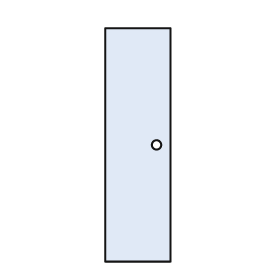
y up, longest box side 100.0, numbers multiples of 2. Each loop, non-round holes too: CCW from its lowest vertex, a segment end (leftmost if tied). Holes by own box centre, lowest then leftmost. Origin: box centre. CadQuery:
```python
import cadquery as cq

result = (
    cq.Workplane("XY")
    .moveTo(-14.0, -50.0)
    .lineTo(14.0, -50.0)
    .lineTo(14.0, 50.0)
    .lineTo(-14.0, 50.0)
    .close()
    .moveTo(8.0, 0.0)
    .circle(2.0)
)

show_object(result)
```